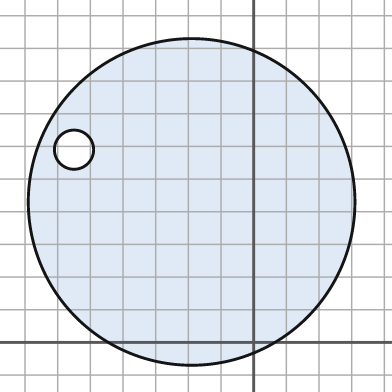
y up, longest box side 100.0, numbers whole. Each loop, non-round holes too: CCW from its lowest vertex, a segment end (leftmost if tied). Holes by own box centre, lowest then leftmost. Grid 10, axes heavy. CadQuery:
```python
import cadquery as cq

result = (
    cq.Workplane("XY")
    .moveTo(-19.0, 43.0)
    .circle(50.0)
    .moveTo(-55.0, 59.0)
    .circle(6.0)
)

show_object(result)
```